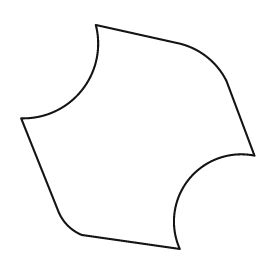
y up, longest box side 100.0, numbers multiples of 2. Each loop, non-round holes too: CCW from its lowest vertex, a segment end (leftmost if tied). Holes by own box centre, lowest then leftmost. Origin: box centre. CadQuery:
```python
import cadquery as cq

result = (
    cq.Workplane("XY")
    .moveTo(18.0, -48.0)
    .threePointArc((22.0, -18.0), (50.0, -8.0))
    .lineTo(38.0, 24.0)
    .threePointArc((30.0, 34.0), (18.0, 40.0))
    .lineTo(-18.0, 48.0)
    .threePointArc((-24.0, 20.0), (-50.0, 8.0))
    .lineTo(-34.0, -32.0)
    .threePointArc((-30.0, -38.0), (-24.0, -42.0))
    .close()
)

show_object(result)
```